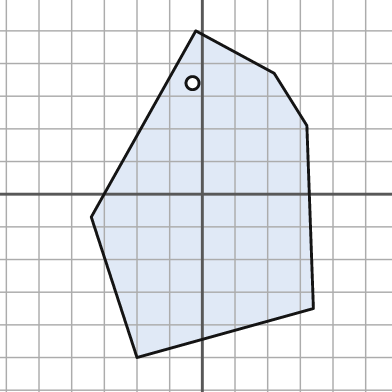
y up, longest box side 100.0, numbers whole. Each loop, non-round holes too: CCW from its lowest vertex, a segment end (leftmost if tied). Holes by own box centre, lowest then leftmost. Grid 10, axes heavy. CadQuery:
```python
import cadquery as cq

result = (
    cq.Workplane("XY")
    .moveTo(-20.0, -50.0)
    .lineTo(34.0, -35.0)
    .lineTo(32.0, 21.0)
    .lineTo(22.0, 37.0)
    .lineTo(-2.0, 50.0)
    .lineTo(-34.0, -7.0)
    .close()
    .moveTo(-3.0, 34.0)
    .circle(2.0)
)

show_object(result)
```